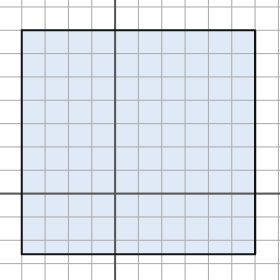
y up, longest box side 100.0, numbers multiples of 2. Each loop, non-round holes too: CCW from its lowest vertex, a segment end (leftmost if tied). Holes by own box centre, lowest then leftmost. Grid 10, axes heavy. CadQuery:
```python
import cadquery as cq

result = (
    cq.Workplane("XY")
    .moveTo(-40.0, -26.0)
    .lineTo(60.0, -26.0)
    .lineTo(60.0, 70.0)
    .lineTo(-40.0, 70.0)
    .close()
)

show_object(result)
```